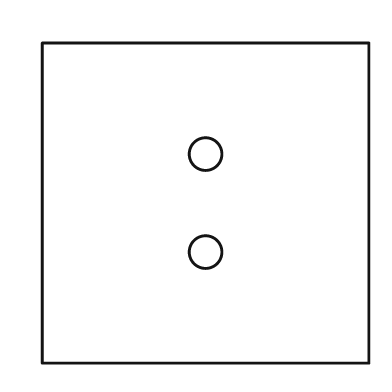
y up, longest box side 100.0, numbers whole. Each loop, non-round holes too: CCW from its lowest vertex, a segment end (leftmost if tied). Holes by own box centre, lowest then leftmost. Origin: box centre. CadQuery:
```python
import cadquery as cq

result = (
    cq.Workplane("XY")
    .moveTo(-50.0, -49.0)
    .lineTo(50.0, -49.0)
    .lineTo(50.0, 49.0)
    .lineTo(-50.0, 49.0)
    .close()
    .moveTo(0.0, -15.0)
    .circle(5.0)
    .moveTo(0.0, 15.0)
    .circle(5.0)
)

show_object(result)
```